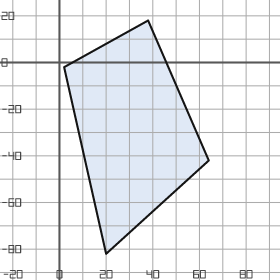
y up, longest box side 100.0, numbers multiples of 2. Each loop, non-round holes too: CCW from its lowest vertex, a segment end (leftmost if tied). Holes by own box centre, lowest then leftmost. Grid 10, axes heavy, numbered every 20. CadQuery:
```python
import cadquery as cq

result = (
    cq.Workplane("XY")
    .moveTo(20.0, -82.0)
    .lineTo(64.0, -42.0)
    .lineTo(38.0, 18.0)
    .lineTo(2.0, -2.0)
    .close()
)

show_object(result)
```